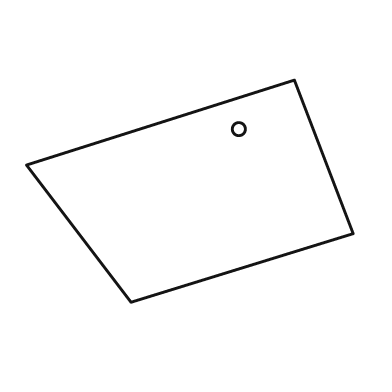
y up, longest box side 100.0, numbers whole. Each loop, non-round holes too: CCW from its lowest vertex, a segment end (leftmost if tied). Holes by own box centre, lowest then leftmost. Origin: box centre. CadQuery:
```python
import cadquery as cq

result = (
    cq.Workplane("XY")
    .moveTo(-18.0, -34.0)
    .lineTo(50.0, -13.0)
    .lineTo(32.0, 34.0)
    .lineTo(-50.0, 8.0)
    .close()
    .moveTo(15.0, 19.0)
    .circle(2.0)
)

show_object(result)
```